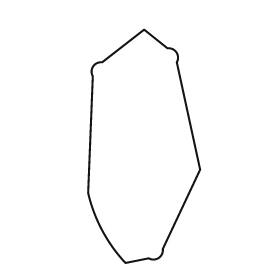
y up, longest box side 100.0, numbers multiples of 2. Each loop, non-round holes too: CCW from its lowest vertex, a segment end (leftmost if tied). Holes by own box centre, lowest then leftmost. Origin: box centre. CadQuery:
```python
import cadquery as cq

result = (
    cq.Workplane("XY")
    .moveTo(-8.0, -50.0)
    .lineTo(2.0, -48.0)
    .threePointArc((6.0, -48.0), (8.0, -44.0))
    .lineTo(24.0, -10.0)
    .lineTo(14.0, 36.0)
    .threePointArc((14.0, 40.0), (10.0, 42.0))
    .lineTo(0.0, 50.0)
    .lineTo(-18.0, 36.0)
    .threePointArc((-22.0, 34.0), (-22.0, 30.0))
    .lineTo(-24.0, -20.0)
    .threePointArc((-18.0, -36.0), (-8.0, -50.0))
    .close()
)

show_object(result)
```